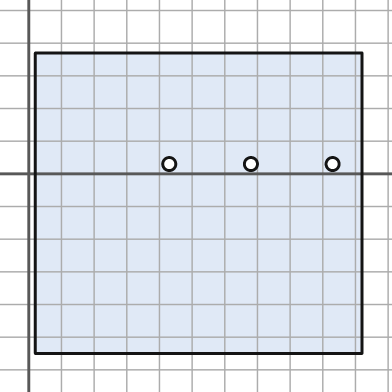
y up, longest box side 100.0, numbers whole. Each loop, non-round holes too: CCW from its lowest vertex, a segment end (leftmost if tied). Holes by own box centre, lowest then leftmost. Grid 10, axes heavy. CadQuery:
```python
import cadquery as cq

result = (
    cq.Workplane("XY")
    .moveTo(2.0, -55.0)
    .lineTo(102.0, -55.0)
    .lineTo(102.0, 37.0)
    .lineTo(2.0, 37.0)
    .close()
    .moveTo(43.0, 3.0)
    .circle(2.0)
    .moveTo(68.0, 3.0)
    .circle(2.0)
    .moveTo(93.0, 3.0)
    .circle(2.0)
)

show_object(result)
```